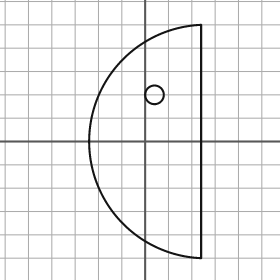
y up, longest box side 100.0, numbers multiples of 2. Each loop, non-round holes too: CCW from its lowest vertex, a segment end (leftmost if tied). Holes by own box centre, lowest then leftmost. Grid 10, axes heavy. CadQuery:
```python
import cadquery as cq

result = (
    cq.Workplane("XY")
    .moveTo(24.0, -50.0)
    .lineTo(24.0, 50.0)
    .threePointArc((-24.0, 0.0), (24.0, -50.0))
    .close()
    .moveTo(4.0, 20.0)
    .circle(4.0)
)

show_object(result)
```